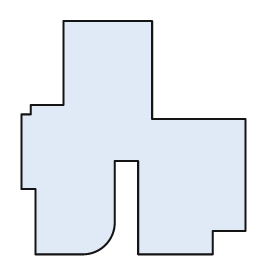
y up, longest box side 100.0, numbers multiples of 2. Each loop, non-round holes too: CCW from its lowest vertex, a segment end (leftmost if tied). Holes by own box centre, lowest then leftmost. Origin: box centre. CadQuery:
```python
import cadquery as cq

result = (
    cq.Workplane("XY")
    .moveTo(-42.0, -50.0)
    .lineTo(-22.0, -50.0)
    .threePointArc((-12.0, -46.0), (-8.0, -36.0))
    .lineTo(-8.0, -10.0)
    .lineTo(2.0, -10.0)
    .lineTo(2.0, -50.0)
    .lineTo(34.0, -50.0)
    .lineTo(34.0, -40.0)
    .lineTo(48.0, -40.0)
    .lineTo(48.0, 8.0)
    .lineTo(8.0, 8.0)
    .lineTo(8.0, 50.0)
    .lineTo(-30.0, 50.0)
    .lineTo(-30.0, 14.0)
    .lineTo(-44.0, 14.0)
    .lineTo(-44.0, 10.0)
    .lineTo(-48.0, 10.0)
    .lineTo(-48.0, -22.0)
    .lineTo(-42.0, -22.0)
    .close()
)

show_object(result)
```